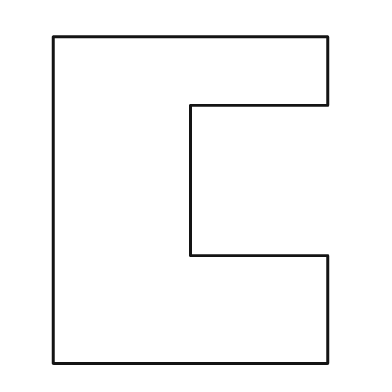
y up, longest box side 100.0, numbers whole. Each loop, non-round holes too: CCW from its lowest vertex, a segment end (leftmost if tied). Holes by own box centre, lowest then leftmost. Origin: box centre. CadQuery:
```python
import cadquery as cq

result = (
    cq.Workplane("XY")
    .moveTo(-42.0, -50.0)
    .lineTo(42.0, -50.0)
    .lineTo(42.0, -17.0)
    .lineTo(0.0, -17.0)
    .lineTo(0.0, 29.0)
    .lineTo(42.0, 29.0)
    .lineTo(42.0, 50.0)
    .lineTo(-42.0, 50.0)
    .close()
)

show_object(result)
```